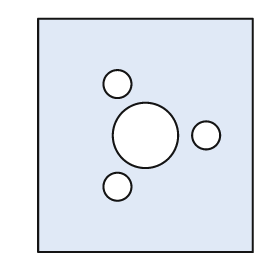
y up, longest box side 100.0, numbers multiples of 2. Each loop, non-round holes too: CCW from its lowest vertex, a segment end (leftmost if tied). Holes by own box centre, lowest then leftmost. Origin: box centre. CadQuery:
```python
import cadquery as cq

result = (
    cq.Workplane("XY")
    .moveTo(-46.0, -50.0)
    .lineTo(46.0, -50.0)
    .lineTo(46.0, 50.0)
    .lineTo(-46.0, 50.0)
    .close()
    .moveTo(-12.0, -22.0)
    .circle(6.0)
    .moveTo(0.0, 0.0)
    .circle(14.0)
    .moveTo(26.0, 0.0)
    .circle(6.0)
    .moveTo(-12.0, 22.0)
    .circle(6.0)
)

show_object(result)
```